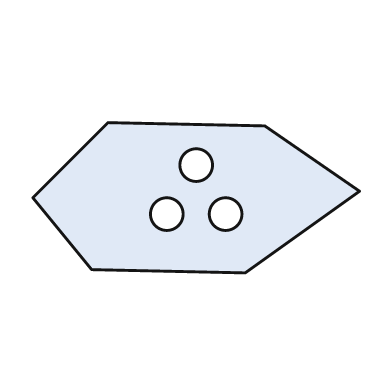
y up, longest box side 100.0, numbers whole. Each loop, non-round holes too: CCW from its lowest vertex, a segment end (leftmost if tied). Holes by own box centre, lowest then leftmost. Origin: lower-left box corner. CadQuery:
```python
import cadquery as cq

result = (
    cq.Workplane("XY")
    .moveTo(65.0, 0.0)
    .lineTo(100.0, 25.0)
    .lineTo(71.0, 45.0)
    .lineTo(23.0, 46.0)
    .lineTo(0.0, 23.0)
    .lineTo(18.0, 1.0)
    .close()
    .moveTo(41.0, 18.0)
    .circle(5.0)
    .moveTo(59.0, 18.0)
    .circle(5.0)
    .moveTo(50.0, 33.0)
    .circle(5.0)
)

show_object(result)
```